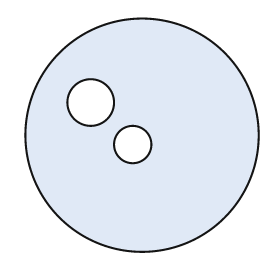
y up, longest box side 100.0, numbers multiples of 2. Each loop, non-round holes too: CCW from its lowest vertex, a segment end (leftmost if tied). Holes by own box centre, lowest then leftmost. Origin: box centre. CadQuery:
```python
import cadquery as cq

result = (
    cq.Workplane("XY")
    .moveTo(0.0, 0.0)
    .circle(50.0)
    .moveTo(-4.0, -4.0)
    .circle(8.0)
    .moveTo(-22.0, 14.0)
    .circle(10.0)
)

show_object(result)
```